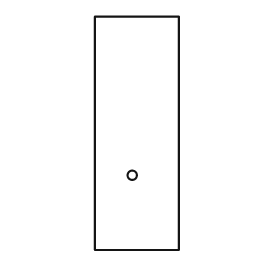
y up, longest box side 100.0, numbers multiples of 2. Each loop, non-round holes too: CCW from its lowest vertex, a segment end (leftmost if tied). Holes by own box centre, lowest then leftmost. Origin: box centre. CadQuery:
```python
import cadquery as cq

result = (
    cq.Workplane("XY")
    .moveTo(-18.0, -50.0)
    .lineTo(18.0, -50.0)
    .lineTo(18.0, 50.0)
    .lineTo(-18.0, 50.0)
    .close()
    .moveTo(-2.0, -18.0)
    .circle(2.0)
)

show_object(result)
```